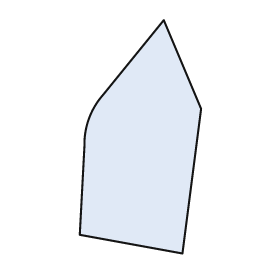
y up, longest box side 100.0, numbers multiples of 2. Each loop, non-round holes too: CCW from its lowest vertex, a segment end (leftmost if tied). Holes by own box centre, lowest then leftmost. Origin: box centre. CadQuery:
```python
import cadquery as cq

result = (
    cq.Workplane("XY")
    .moveTo(18.0, -50.0)
    .lineTo(26.0, 12.0)
    .lineTo(10.0, 50.0)
    .lineTo(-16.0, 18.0)
    .threePointArc((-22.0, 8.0), (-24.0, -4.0))
    .lineTo(-26.0, -42.0)
    .close()
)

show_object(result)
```